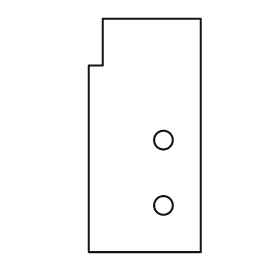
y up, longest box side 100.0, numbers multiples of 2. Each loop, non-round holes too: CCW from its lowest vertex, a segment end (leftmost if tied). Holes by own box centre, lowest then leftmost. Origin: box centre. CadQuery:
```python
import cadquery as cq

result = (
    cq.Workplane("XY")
    .moveTo(-24.0, -50.0)
    .lineTo(24.0, -50.0)
    .lineTo(24.0, 50.0)
    .lineTo(-18.0, 50.0)
    .lineTo(-18.0, 30.0)
    .lineTo(-24.0, 30.0)
    .close()
    .moveTo(8.0, -30.0)
    .circle(4.0)
    .moveTo(8.0, -2.0)
    .circle(4.0)
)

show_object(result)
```